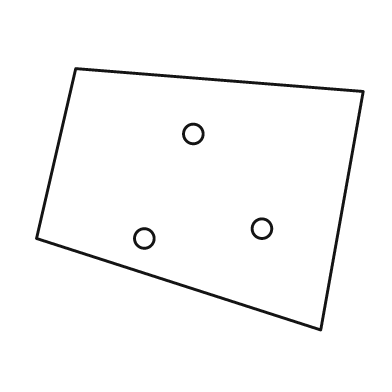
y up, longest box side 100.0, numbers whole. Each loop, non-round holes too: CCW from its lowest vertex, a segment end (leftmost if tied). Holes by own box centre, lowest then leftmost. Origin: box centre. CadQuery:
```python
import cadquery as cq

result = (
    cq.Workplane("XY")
    .moveTo(37.0, -40.0)
    .lineTo(50.0, 33.0)
    .lineTo(-38.0, 40.0)
    .lineTo(-50.0, -12.0)
    .close()
    .moveTo(-17.0, -12.0)
    .circle(3.0)
    .moveTo(19.0, -9.0)
    .circle(3.0)
    .moveTo(-2.0, 20.0)
    .circle(3.0)
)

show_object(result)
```